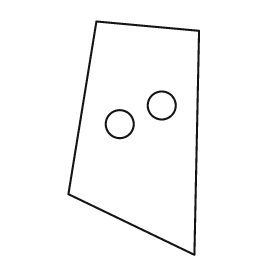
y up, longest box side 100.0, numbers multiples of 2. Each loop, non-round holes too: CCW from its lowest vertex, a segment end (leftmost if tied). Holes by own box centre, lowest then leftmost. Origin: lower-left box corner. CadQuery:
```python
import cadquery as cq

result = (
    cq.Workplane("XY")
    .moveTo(54.0, 0.0)
    .lineTo(56.0, 96.0)
    .lineTo(12.0, 100.0)
    .lineTo(0.0, 26.0)
    .close()
    .moveTo(22.0, 56.0)
    .circle(6.0)
    .moveTo(40.0, 64.0)
    .circle(6.0)
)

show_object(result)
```